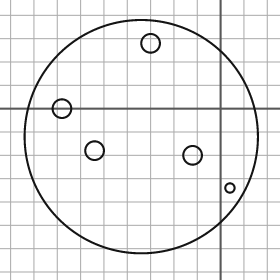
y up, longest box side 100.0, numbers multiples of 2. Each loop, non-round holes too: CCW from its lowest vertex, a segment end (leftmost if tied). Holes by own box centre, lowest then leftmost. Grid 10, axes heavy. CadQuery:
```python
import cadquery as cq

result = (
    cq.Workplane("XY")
    .moveTo(-34.0, -12.0)
    .circle(50.0)
    .moveTo(4.0, -34.0)
    .circle(2.0)
    .moveTo(-12.0, -20.0)
    .circle(4.0)
    .moveTo(-54.0, -18.0)
    .circle(4.0)
    .moveTo(-68.0, 0.0)
    .circle(4.0)
    .moveTo(-30.0, 28.0)
    .circle(4.0)
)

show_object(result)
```